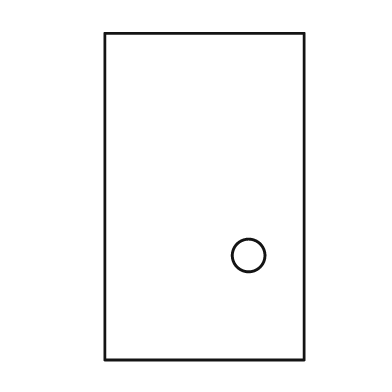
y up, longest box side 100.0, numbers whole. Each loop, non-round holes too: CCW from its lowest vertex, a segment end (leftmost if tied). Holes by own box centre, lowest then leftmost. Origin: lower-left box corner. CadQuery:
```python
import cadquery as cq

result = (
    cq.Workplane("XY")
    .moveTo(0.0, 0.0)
    .lineTo(61.0, 0.0)
    .lineTo(61.0, 100.0)
    .lineTo(0.0, 100.0)
    .close()
    .moveTo(44.0, 32.0)
    .circle(5.0)
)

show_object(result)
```